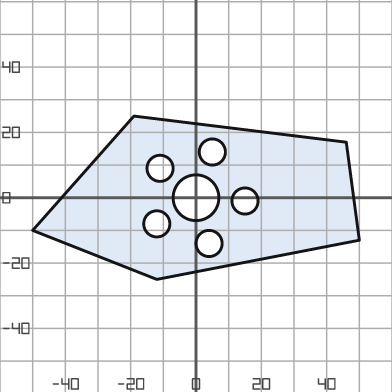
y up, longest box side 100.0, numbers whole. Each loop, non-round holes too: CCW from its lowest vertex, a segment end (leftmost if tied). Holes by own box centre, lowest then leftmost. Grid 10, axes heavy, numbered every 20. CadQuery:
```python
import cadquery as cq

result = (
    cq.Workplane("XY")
    .moveTo(-12.0, -25.0)
    .lineTo(50.0, -13.0)
    .lineTo(46.0, 17.0)
    .lineTo(-19.0, 25.0)
    .lineTo(-50.0, -10.0)
    .close()
    .moveTo(4.0, -14.0)
    .circle(4.0)
    .moveTo(-12.0, -8.0)
    .circle(4.0)
    .moveTo(15.0, -1.0)
    .circle(4.0)
    .moveTo(0.0, 0.0)
    .circle(7.0)
    .moveTo(-11.0, 9.0)
    .circle(4.0)
    .moveTo(5.0, 14.0)
    .circle(4.0)
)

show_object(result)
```